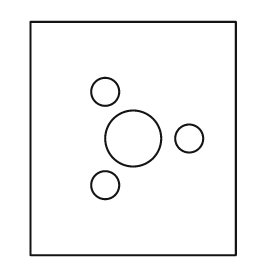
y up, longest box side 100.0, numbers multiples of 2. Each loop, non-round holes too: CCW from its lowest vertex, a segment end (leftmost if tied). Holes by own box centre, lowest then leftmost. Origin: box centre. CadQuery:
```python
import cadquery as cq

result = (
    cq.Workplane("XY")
    .moveTo(-44.0, -50.0)
    .lineTo(44.0, -50.0)
    .lineTo(44.0, 50.0)
    .lineTo(-44.0, 50.0)
    .close()
    .moveTo(-12.0, -20.0)
    .circle(6.0)
    .moveTo(0.0, 0.0)
    .circle(12.0)
    .moveTo(24.0, 0.0)
    .circle(6.0)
    .moveTo(-12.0, 20.0)
    .circle(6.0)
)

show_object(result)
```